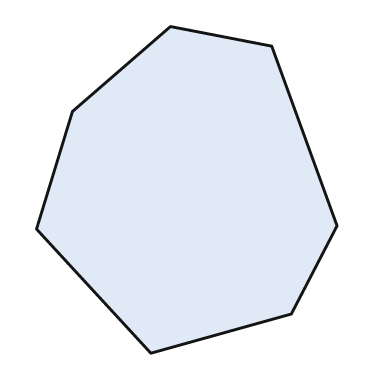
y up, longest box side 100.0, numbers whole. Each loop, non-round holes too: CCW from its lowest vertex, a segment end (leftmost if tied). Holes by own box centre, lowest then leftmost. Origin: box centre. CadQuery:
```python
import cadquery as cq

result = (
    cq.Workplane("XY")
    .moveTo(-11.0, -50.0)
    .lineTo(32.0, -38.0)
    .lineTo(46.0, -11.0)
    .lineTo(26.0, 44.0)
    .lineTo(-5.0, 50.0)
    .lineTo(-35.0, 24.0)
    .lineTo(-46.0, -12.0)
    .close()
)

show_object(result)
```